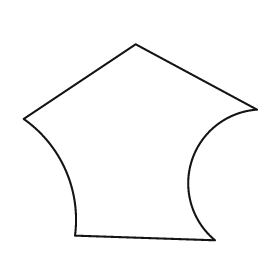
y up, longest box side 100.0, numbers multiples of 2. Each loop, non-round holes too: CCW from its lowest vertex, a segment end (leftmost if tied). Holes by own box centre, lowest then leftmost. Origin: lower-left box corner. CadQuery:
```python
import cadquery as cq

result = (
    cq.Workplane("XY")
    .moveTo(82.0, 0.0)
    .threePointArc((72.0, 34.0), (100.0, 56.0))
    .lineTo(48.0, 84.0)
    .lineTo(0.0, 52.0)
    .threePointArc((18.0, 30.0), (22.0, 2.0))
    .close()
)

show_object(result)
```